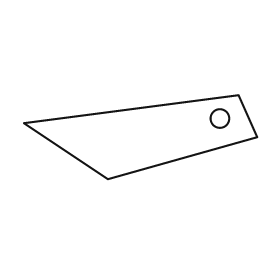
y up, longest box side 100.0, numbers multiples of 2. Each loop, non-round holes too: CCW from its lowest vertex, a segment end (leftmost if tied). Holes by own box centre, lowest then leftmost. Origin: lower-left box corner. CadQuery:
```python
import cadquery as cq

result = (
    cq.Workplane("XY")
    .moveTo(36.0, 0.0)
    .lineTo(100.0, 18.0)
    .lineTo(92.0, 36.0)
    .lineTo(0.0, 24.0)
    .close()
    .moveTo(84.0, 26.0)
    .circle(4.0)
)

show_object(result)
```